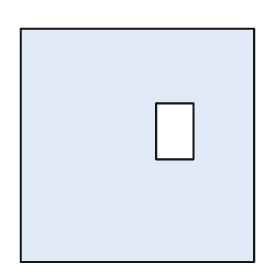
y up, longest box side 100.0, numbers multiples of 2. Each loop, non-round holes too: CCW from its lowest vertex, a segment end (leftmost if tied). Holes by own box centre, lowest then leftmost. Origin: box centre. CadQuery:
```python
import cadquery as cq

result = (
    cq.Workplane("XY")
    .moveTo(-50.0, -50.0)
    .lineTo(50.0, -50.0)
    .lineTo(50.0, 50.0)
    .lineTo(-50.0, 50.0)
    .close()
    .moveTo(8.0, -6.0)
    .lineTo(24.0, -6.0)
    .lineTo(24.0, 18.0)
    .lineTo(8.0, 18.0)
    .close()
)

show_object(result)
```